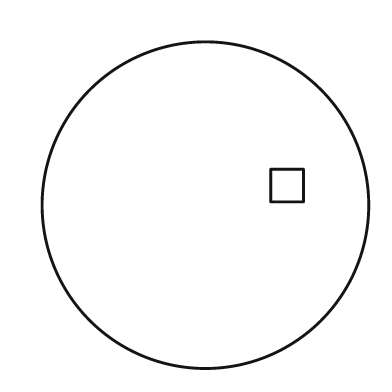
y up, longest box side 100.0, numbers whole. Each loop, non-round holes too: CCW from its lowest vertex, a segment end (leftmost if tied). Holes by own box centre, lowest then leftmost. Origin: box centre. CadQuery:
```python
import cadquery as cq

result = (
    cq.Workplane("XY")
    .moveTo(0.0, 0.0)
    .circle(50.0)
    .moveTo(20.0, 1.0)
    .lineTo(30.0, 1.0)
    .lineTo(30.0, 11.0)
    .lineTo(20.0, 11.0)
    .close()
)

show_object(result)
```